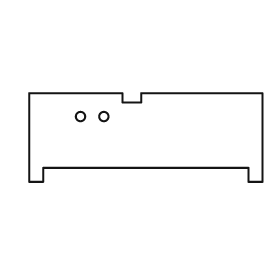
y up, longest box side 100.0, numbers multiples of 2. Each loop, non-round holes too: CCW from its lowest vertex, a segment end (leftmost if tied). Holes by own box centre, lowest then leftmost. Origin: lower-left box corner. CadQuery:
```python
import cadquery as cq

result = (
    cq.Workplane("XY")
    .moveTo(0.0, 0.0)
    .lineTo(6.0, 0.0)
    .lineTo(6.0, 6.0)
    .lineTo(94.0, 6.0)
    .lineTo(94.0, 0.0)
    .lineTo(100.0, 0.0)
    .lineTo(100.0, 38.0)
    .lineTo(48.0, 38.0)
    .lineTo(48.0, 34.0)
    .lineTo(40.0, 34.0)
    .lineTo(40.0, 38.0)
    .lineTo(0.0, 38.0)
    .close()
    .moveTo(22.0, 28.0)
    .circle(2.0)
    .moveTo(32.0, 28.0)
    .circle(2.0)
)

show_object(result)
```